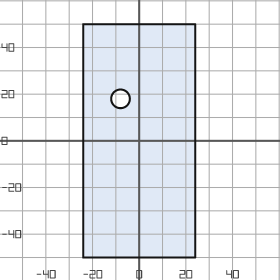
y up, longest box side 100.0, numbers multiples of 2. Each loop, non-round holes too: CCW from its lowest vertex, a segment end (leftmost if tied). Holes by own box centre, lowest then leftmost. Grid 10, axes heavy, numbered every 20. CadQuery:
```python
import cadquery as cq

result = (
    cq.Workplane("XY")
    .moveTo(-24.0, -50.0)
    .lineTo(24.0, -50.0)
    .lineTo(24.0, 50.0)
    .lineTo(-24.0, 50.0)
    .close()
    .moveTo(-8.0, 18.0)
    .circle(4.0)
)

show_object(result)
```